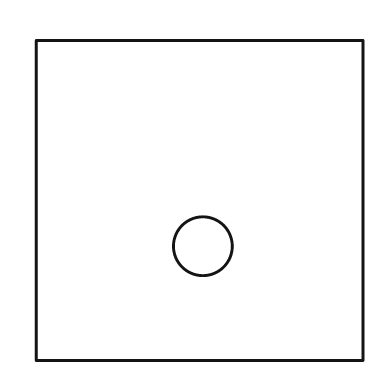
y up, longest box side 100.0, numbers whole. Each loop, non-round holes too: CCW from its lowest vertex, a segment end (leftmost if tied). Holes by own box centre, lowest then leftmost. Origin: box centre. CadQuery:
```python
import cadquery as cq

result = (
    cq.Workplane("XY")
    .moveTo(-50.0, -49.0)
    .lineTo(50.0, -49.0)
    .lineTo(50.0, 49.0)
    .lineTo(-50.0, 49.0)
    .close()
    .moveTo(1.0, -14.0)
    .circle(9.0)
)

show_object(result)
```